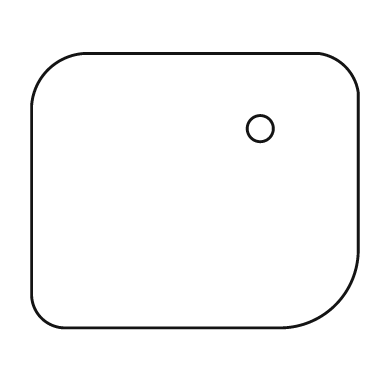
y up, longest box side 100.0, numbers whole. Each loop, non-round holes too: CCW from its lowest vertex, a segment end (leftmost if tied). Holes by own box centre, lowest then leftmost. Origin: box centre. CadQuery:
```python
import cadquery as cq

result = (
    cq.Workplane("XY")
    .moveTo(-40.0, -42.0)
    .lineTo(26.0, -42.0)
    .threePointArc((43.0, -35.0), (50.0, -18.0))
    .lineTo(50.0, 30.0)
    .threePointArc((46.0, 38.0), (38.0, 42.0))
    .lineTo(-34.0, 42.0)
    .threePointArc((-45.0, 37.0), (-50.0, 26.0))
    .lineTo(-50.0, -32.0)
    .threePointArc((-47.0, -39.0), (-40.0, -42.0))
    .close()
    .moveTo(20.0, 19.0)
    .circle(4.0)
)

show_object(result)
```